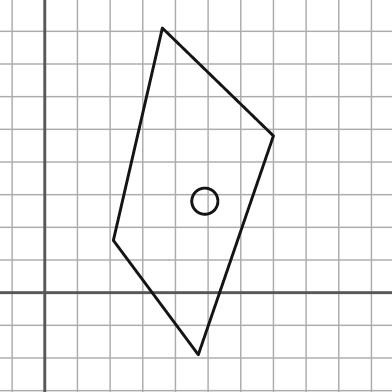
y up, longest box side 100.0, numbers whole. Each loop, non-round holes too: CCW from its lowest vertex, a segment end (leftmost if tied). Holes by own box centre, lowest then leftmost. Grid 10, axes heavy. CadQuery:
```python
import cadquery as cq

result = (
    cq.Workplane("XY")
    .moveTo(47.0, -19.0)
    .lineTo(70.0, 48.0)
    .lineTo(36.0, 81.0)
    .lineTo(21.0, 16.0)
    .close()
    .moveTo(49.0, 28.0)
    .circle(4.0)
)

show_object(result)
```